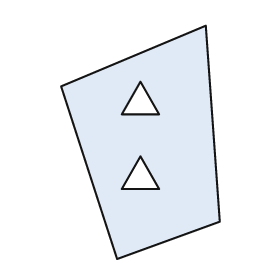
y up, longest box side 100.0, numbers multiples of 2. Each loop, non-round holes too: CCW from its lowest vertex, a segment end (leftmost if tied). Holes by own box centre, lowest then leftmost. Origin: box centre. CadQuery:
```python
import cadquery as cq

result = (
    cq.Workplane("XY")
    .moveTo(-10.0, -50.0)
    .lineTo(34.0, -34.0)
    .lineTo(28.0, 50.0)
    .lineTo(-34.0, 24.0)
    .close()
    .moveTo(-8.0, -20.0)
    .lineTo(8.0, -20.0)
    .lineTo(0.0, -6.0)
    .close()
    .moveTo(-8.0, 12.0)
    .lineTo(8.0, 12.0)
    .lineTo(0.0, 26.0)
    .close()
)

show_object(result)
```